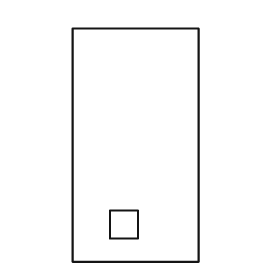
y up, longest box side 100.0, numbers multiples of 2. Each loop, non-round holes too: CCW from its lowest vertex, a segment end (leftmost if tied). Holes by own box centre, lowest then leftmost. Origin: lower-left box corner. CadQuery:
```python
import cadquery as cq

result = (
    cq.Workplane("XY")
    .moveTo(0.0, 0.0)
    .lineTo(54.0, 0.0)
    .lineTo(54.0, 100.0)
    .lineTo(0.0, 100.0)
    .close()
    .moveTo(16.0, 10.0)
    .lineTo(28.0, 10.0)
    .lineTo(28.0, 22.0)
    .lineTo(16.0, 22.0)
    .close()
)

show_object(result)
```